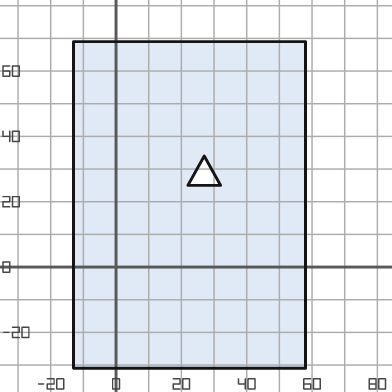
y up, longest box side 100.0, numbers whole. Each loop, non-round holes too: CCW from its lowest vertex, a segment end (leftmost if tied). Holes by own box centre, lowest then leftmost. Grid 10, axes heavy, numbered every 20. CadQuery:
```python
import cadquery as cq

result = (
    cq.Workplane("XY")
    .moveTo(-13.0, -31.0)
    .lineTo(58.0, -31.0)
    .lineTo(58.0, 69.0)
    .lineTo(-13.0, 69.0)
    .close()
    .moveTo(22.0, 25.0)
    .lineTo(32.0, 25.0)
    .lineTo(27.0, 34.0)
    .close()
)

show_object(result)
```